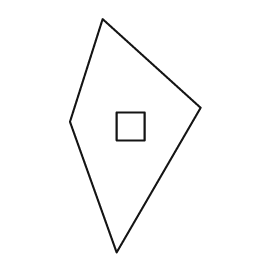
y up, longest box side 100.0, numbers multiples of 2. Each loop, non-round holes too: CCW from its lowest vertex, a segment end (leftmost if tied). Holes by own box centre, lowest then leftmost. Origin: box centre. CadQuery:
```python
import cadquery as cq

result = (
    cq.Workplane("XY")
    .moveTo(-8.0, -50.0)
    .lineTo(28.0, 12.0)
    .lineTo(-14.0, 50.0)
    .lineTo(-28.0, 6.0)
    .close()
    .moveTo(-8.0, -2.0)
    .lineTo(4.0, -2.0)
    .lineTo(4.0, 10.0)
    .lineTo(-8.0, 10.0)
    .close()
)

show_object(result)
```